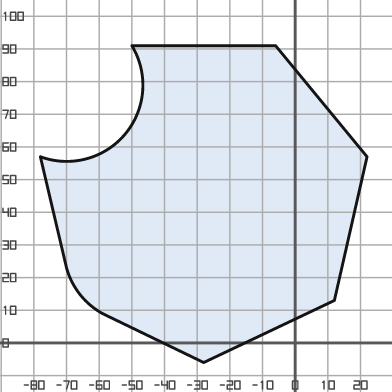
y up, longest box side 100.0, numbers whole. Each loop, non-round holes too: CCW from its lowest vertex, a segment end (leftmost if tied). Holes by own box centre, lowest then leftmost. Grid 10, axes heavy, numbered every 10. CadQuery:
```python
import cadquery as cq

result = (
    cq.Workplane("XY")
    .moveTo(-28.0, -6.0)
    .lineTo(12.0, 13.0)
    .lineTo(22.0, 57.0)
    .lineTo(-6.0, 91.0)
    .lineTo(-50.0, 91.0)
    .threePointArc((-52.0, 64.0), (-78.0, 57.0))
    .lineTo(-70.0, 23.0)
    .threePointArc((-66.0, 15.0), (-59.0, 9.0))
    .close()
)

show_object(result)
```